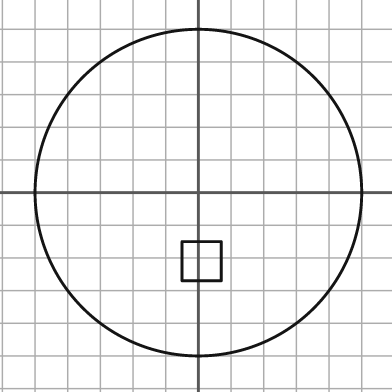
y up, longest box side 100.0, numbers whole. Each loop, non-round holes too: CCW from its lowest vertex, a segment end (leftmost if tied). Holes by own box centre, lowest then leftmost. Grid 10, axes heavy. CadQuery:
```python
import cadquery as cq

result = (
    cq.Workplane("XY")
    .moveTo(0.0, 0.0)
    .circle(50.0)
    .moveTo(-5.0, -27.0)
    .lineTo(7.0, -27.0)
    .lineTo(7.0, -15.0)
    .lineTo(-5.0, -15.0)
    .close()
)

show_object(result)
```